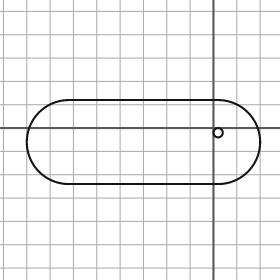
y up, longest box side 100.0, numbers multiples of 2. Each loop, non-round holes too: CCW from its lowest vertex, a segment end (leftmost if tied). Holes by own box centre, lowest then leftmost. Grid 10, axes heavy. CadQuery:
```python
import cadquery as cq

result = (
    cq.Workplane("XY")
    .moveTo(-62.0, -24.0)
    .lineTo(2.0, -24.0)
    .threePointArc((20.0, -6.0), (2.0, 12.0))
    .lineTo(-62.0, 12.0)
    .threePointArc((-80.0, -6.0), (-62.0, -24.0))
    .close()
    .moveTo(2.0, -2.0)
    .circle(2.0)
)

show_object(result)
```